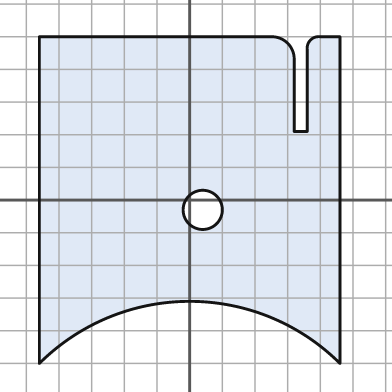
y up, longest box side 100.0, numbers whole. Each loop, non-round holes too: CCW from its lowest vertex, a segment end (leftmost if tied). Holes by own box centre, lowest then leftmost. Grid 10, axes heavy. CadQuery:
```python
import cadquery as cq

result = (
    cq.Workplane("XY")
    .moveTo(-46.0, -50.0)
    .threePointArc((0.0, -31.0), (46.0, -50.0))
    .lineTo(46.0, 50.0)
    .lineTo(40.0, 50.0)
    .threePointArc((37.0, 49.0), (36.0, 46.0))
    .lineTo(36.0, 21.0)
    .lineTo(32.0, 21.0)
    .lineTo(32.0, 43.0)
    .threePointArc((30.0, 48.0), (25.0, 50.0))
    .lineTo(-46.0, 50.0)
    .close()
    .moveTo(4.0, -3.0)
    .circle(6.0)
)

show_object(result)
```